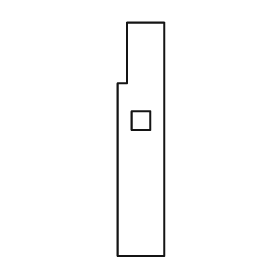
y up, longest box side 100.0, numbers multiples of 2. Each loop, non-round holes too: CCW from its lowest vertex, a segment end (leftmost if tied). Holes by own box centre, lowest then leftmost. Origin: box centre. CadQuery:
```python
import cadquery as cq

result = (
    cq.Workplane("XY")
    .moveTo(-10.0, -50.0)
    .lineTo(10.0, -50.0)
    .lineTo(10.0, 50.0)
    .lineTo(-6.0, 50.0)
    .lineTo(-6.0, 24.0)
    .lineTo(-10.0, 24.0)
    .close()
    .moveTo(-4.0, 4.0)
    .lineTo(4.0, 4.0)
    .lineTo(4.0, 12.0)
    .lineTo(-4.0, 12.0)
    .close()
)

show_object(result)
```